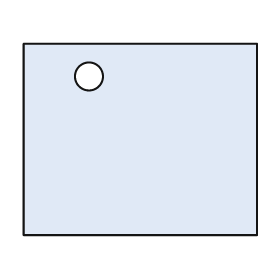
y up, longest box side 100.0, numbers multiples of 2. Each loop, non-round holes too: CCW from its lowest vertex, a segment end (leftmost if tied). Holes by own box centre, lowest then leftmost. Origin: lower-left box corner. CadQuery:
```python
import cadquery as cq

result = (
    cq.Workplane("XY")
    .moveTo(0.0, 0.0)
    .lineTo(100.0, 0.0)
    .lineTo(100.0, 82.0)
    .lineTo(0.0, 82.0)
    .close()
    .moveTo(28.0, 68.0)
    .circle(6.0)
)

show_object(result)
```